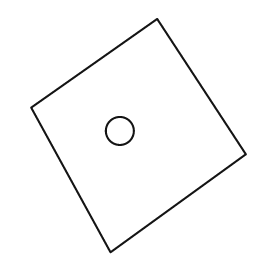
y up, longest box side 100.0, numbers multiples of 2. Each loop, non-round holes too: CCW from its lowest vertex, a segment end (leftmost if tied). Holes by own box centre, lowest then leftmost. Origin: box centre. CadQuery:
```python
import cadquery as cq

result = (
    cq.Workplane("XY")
    .moveTo(-12.0, -50.0)
    .lineTo(46.0, -8.0)
    .lineTo(8.0, 50.0)
    .lineTo(-46.0, 12.0)
    .close()
    .moveTo(-8.0, 2.0)
    .circle(6.0)
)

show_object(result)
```